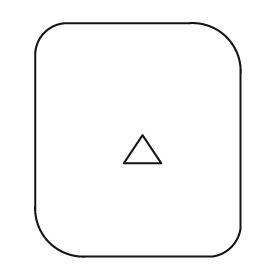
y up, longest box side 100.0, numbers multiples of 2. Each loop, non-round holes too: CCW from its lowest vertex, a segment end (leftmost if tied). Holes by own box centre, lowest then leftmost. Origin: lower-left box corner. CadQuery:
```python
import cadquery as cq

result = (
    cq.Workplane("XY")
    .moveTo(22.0, 0.0)
    .lineTo(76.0, 0.0)
    .threePointArc((84.0, 4.0), (88.0, 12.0))
    .lineTo(88.0, 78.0)
    .threePointArc((82.0, 94.0), (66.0, 100.0))
    .lineTo(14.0, 100.0)
    .threePointArc((4.0, 96.0), (0.0, 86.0))
    .lineTo(0.0, 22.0)
    .threePointArc((6.0, 6.0), (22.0, 0.0))
    .close()
    .moveTo(38.0, 40.0)
    .lineTo(54.0, 40.0)
    .lineTo(46.0, 52.0)
    .close()
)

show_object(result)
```